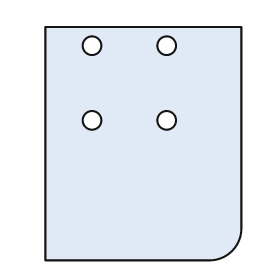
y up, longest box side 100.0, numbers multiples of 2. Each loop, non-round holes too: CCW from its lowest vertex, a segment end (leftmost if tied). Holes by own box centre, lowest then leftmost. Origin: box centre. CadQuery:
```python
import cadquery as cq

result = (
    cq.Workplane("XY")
    .moveTo(-42.0, -50.0)
    .lineTo(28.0, -50.0)
    .threePointArc((38.0, -46.0), (42.0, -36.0))
    .lineTo(42.0, 50.0)
    .lineTo(-42.0, 50.0)
    .close()
    .moveTo(-22.0, 10.0)
    .circle(4.0)
    .moveTo(10.0, 10.0)
    .circle(4.0)
    .moveTo(-22.0, 42.0)
    .circle(4.0)
    .moveTo(10.0, 42.0)
    .circle(4.0)
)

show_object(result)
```